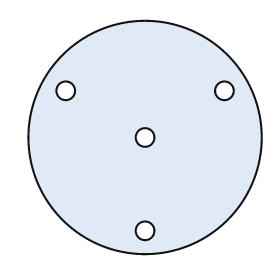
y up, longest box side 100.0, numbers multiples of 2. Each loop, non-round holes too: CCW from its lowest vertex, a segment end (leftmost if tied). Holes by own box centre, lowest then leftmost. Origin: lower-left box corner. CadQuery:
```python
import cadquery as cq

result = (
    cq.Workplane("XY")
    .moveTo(50.0, 50.0)
    .circle(50.0)
    .moveTo(50.0, 10.0)
    .circle(4.0)
    .moveTo(50.0, 50.0)
    .circle(4.0)
    .moveTo(16.0, 70.0)
    .circle(4.0)
    .moveTo(84.0, 70.0)
    .circle(4.0)
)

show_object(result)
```